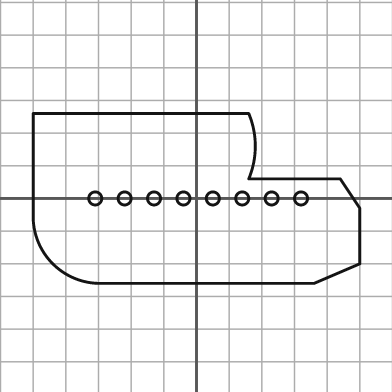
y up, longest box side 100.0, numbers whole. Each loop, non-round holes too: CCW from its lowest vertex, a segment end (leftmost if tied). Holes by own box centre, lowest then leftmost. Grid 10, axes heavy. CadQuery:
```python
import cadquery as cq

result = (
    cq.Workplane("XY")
    .moveTo(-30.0, -26.0)
    .lineTo(36.0, -26.0)
    .lineTo(50.0, -20.0)
    .lineTo(50.0, -3.0)
    .lineTo(44.0, 6.0)
    .lineTo(16.0, 6.0)
    .threePointArc((18.0, 16.0), (16.0, 26.0))
    .lineTo(-50.0, 26.0)
    .lineTo(-50.0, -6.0)
    .threePointArc((-44.0, -20.0), (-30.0, -26.0))
    .close()
    .moveTo(-31.0, 0.0)
    .circle(2.0)
    .moveTo(-22.0, 0.0)
    .circle(2.0)
    .moveTo(-13.0, 0.0)
    .circle(2.0)
    .moveTo(-4.0, 0.0)
    .circle(2.0)
    .moveTo(5.0, 0.0)
    .circle(2.0)
    .moveTo(14.0, 0.0)
    .circle(2.0)
    .moveTo(23.0, 0.0)
    .circle(2.0)
    .moveTo(32.0, 0.0)
    .circle(2.0)
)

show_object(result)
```